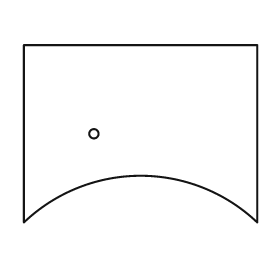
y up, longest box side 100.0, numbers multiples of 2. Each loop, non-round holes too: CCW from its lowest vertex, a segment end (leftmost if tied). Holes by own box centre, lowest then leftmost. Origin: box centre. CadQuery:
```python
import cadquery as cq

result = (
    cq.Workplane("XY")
    .moveTo(-50.0, -38.0)
    .threePointArc((0.0, -18.0), (50.0, -38.0))
    .lineTo(50.0, 38.0)
    .lineTo(-50.0, 38.0)
    .close()
    .moveTo(-20.0, 0.0)
    .circle(2.0)
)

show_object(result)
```